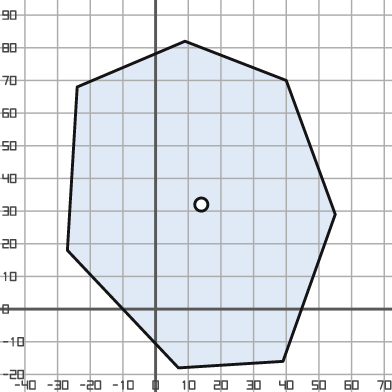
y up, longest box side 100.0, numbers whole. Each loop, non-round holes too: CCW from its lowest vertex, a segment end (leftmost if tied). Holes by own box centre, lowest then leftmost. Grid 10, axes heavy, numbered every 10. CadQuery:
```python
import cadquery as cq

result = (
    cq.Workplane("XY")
    .moveTo(7.0, -18.0)
    .lineTo(39.0, -16.0)
    .lineTo(55.0, 29.0)
    .lineTo(40.0, 70.0)
    .lineTo(9.0, 82.0)
    .lineTo(-24.0, 68.0)
    .lineTo(-27.0, 18.0)
    .close()
    .moveTo(14.0, 32.0)
    .circle(2.0)
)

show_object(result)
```